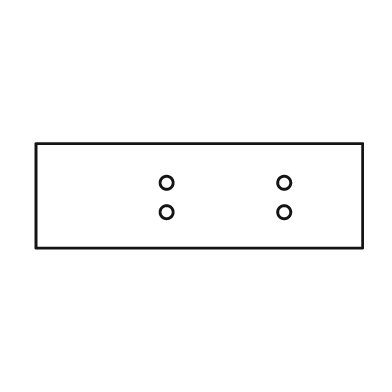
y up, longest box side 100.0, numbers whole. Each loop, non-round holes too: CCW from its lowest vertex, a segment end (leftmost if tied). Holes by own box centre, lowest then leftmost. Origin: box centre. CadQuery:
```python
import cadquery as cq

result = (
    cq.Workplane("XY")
    .moveTo(-50.0, -16.0)
    .lineTo(50.0, -16.0)
    .lineTo(50.0, 16.0)
    .lineTo(-50.0, 16.0)
    .close()
    .moveTo(-10.0, -5.0)
    .circle(2.0)
    .moveTo(26.0, -5.0)
    .circle(2.0)
    .moveTo(-10.0, 4.0)
    .circle(2.0)
    .moveTo(26.0, 4.0)
    .circle(2.0)
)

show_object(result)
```